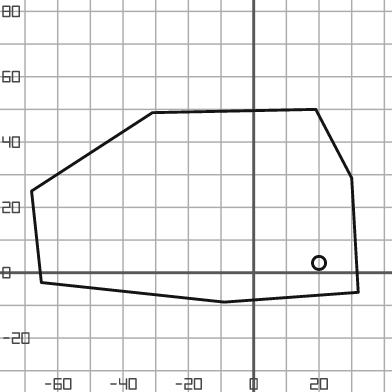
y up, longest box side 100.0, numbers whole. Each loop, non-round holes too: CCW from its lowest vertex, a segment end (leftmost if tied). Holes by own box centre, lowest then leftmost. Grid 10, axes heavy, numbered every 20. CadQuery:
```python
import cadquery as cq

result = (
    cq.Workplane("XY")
    .moveTo(-9.0, -9.0)
    .lineTo(32.0, -6.0)
    .lineTo(30.0, 29.0)
    .lineTo(19.0, 50.0)
    .lineTo(-31.0, 49.0)
    .lineTo(-68.0, 25.0)
    .lineTo(-65.0, -3.0)
    .close()
    .moveTo(20.0, 3.0)
    .circle(2.0)
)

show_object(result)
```